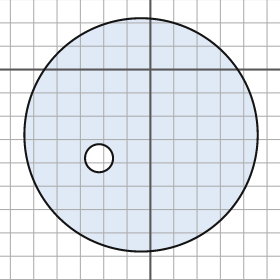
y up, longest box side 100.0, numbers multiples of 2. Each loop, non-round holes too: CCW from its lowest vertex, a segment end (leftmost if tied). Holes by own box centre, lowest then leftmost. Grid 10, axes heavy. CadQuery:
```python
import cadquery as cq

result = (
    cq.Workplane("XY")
    .moveTo(-4.0, -28.0)
    .circle(50.0)
    .moveTo(-22.0, -38.0)
    .circle(6.0)
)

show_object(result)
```